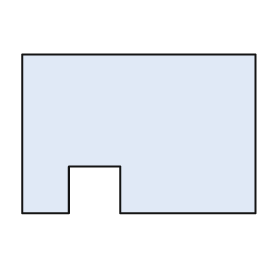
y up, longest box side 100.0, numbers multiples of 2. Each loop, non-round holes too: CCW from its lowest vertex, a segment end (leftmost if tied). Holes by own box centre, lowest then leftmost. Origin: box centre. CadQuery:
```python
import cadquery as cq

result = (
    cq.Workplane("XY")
    .moveTo(-50.0, -34.0)
    .lineTo(-30.0, -34.0)
    .lineTo(-30.0, -14.0)
    .lineTo(-8.0, -14.0)
    .lineTo(-8.0, -34.0)
    .lineTo(50.0, -34.0)
    .lineTo(50.0, 34.0)
    .lineTo(-50.0, 34.0)
    .close()
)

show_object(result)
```